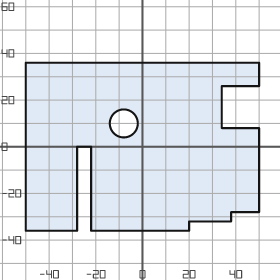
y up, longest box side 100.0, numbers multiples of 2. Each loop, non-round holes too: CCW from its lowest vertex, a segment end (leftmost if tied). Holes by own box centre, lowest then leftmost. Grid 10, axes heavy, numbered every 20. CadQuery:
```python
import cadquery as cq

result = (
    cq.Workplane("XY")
    .moveTo(-50.0, -36.0)
    .lineTo(-28.0, -36.0)
    .lineTo(-28.0, 0.0)
    .lineTo(-22.0, 0.0)
    .lineTo(-22.0, -36.0)
    .lineTo(20.0, -36.0)
    .lineTo(20.0, -32.0)
    .lineTo(38.0, -32.0)
    .lineTo(38.0, -28.0)
    .lineTo(50.0, -28.0)
    .lineTo(50.0, 8.0)
    .lineTo(34.0, 8.0)
    .lineTo(34.0, 26.0)
    .lineTo(50.0, 26.0)
    .lineTo(50.0, 36.0)
    .lineTo(-50.0, 36.0)
    .close()
    .moveTo(-8.0, 10.0)
    .circle(6.0)
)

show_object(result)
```